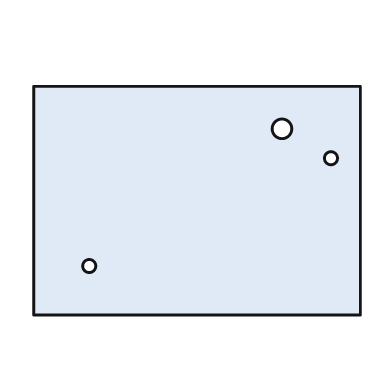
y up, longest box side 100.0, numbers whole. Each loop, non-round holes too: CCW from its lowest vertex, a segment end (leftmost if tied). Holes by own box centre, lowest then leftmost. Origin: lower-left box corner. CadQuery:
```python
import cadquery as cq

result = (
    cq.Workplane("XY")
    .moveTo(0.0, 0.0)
    .lineTo(100.0, 0.0)
    .lineTo(100.0, 70.0)
    .lineTo(0.0, 70.0)
    .close()
    .moveTo(17.0, 15.0)
    .circle(2.0)
    .moveTo(91.0, 48.0)
    .circle(2.0)
    .moveTo(76.0, 57.0)
    .circle(3.0)
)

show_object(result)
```